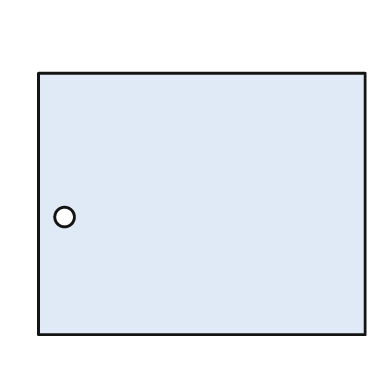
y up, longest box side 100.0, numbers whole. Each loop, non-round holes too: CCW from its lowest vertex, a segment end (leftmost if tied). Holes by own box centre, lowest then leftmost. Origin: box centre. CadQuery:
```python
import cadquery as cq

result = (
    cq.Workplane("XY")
    .moveTo(-50.0, -40.0)
    .lineTo(50.0, -40.0)
    .lineTo(50.0, 40.0)
    .lineTo(-50.0, 40.0)
    .close()
    .moveTo(-42.0, -4.0)
    .circle(3.0)
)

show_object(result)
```